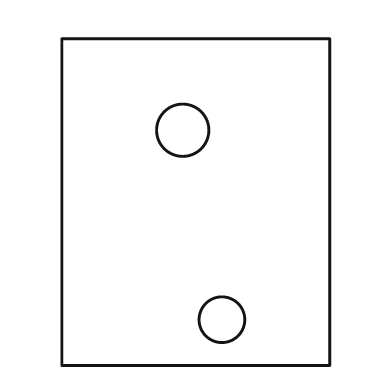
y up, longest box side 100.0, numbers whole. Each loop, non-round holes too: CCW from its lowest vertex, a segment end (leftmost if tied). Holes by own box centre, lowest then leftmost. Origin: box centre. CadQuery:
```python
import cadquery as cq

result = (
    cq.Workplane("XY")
    .moveTo(-41.0, -50.0)
    .lineTo(41.0, -50.0)
    .lineTo(41.0, 50.0)
    .lineTo(-41.0, 50.0)
    .close()
    .moveTo(8.0, -36.0)
    .circle(7.0)
    .moveTo(-4.0, 22.0)
    .circle(8.0)
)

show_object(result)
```